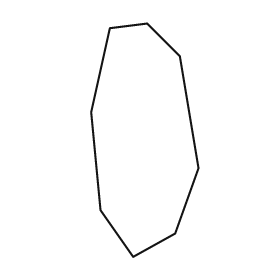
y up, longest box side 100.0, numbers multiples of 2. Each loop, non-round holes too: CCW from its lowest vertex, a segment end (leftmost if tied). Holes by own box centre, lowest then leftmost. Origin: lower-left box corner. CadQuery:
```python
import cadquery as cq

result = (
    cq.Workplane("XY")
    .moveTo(18.0, 0.0)
    .lineTo(36.0, 10.0)
    .lineTo(46.0, 38.0)
    .lineTo(38.0, 86.0)
    .lineTo(24.0, 100.0)
    .lineTo(8.0, 98.0)
    .lineTo(0.0, 62.0)
    .lineTo(4.0, 20.0)
    .close()
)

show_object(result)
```